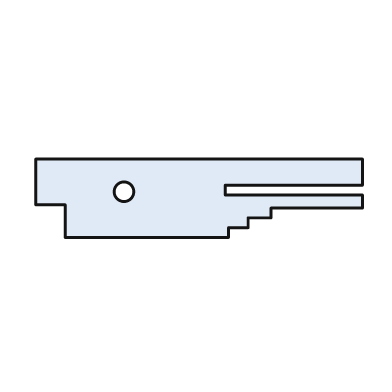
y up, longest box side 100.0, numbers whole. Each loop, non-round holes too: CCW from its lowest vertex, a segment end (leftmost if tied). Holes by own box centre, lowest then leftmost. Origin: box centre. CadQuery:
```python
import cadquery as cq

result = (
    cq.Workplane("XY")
    .moveTo(-41.0, -12.0)
    .lineTo(9.0, -12.0)
    .lineTo(9.0, -9.0)
    .lineTo(15.0, -9.0)
    .lineTo(15.0, -6.0)
    .lineTo(22.0, -6.0)
    .lineTo(22.0, -3.0)
    .lineTo(50.0, -3.0)
    .lineTo(50.0, 1.0)
    .lineTo(8.0, 1.0)
    .lineTo(8.0, 4.0)
    .lineTo(50.0, 4.0)
    .lineTo(50.0, 12.0)
    .lineTo(-50.0, 12.0)
    .lineTo(-50.0, -2.0)
    .lineTo(-41.0, -2.0)
    .close()
    .moveTo(-23.0, 2.0)
    .circle(3.0)
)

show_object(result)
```